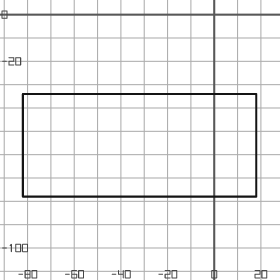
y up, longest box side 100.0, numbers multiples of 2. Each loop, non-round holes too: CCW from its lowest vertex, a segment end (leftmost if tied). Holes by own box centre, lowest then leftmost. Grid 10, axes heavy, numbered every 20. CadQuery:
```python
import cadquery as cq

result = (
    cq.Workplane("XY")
    .moveTo(-82.0, -78.0)
    .lineTo(18.0, -78.0)
    .lineTo(18.0, -34.0)
    .lineTo(-82.0, -34.0)
    .close()
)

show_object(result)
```